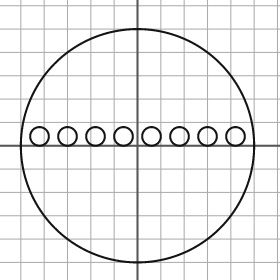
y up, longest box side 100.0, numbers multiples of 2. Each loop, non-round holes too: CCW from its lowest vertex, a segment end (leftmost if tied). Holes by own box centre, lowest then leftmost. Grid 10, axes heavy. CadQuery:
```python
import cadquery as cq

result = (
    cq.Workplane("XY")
    .moveTo(0.0, 0.0)
    .circle(50.0)
    .moveTo(-42.0, 4.0)
    .circle(4.0)
    .moveTo(-30.0, 4.0)
    .circle(4.0)
    .moveTo(-18.0, 4.0)
    .circle(4.0)
    .moveTo(-6.0, 4.0)
    .circle(4.0)
    .moveTo(6.0, 4.0)
    .circle(4.0)
    .moveTo(18.0, 4.0)
    .circle(4.0)
    .moveTo(30.0, 4.0)
    .circle(4.0)
    .moveTo(42.0, 4.0)
    .circle(4.0)
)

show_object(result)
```